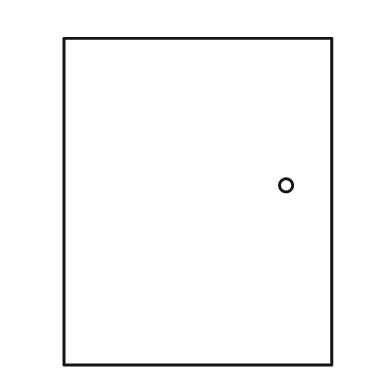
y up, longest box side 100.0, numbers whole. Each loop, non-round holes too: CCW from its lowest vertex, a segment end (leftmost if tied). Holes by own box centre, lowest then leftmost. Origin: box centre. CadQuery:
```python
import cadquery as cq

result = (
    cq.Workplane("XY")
    .moveTo(-41.0, -50.0)
    .lineTo(41.0, -50.0)
    .lineTo(41.0, 50.0)
    .lineTo(-41.0, 50.0)
    .close()
    .moveTo(27.0, 5.0)
    .circle(2.0)
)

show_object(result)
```